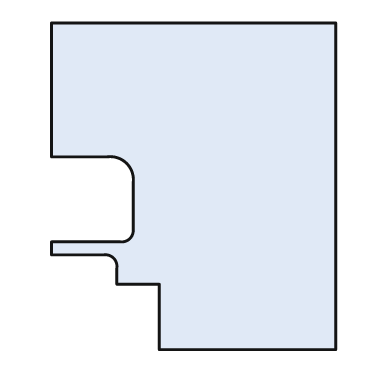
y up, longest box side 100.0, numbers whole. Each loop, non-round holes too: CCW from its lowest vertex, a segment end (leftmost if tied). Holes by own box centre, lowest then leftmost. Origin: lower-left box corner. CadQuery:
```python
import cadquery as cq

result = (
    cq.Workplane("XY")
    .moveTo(33.0, 0.0)
    .lineTo(87.0, 0.0)
    .lineTo(87.0, 100.0)
    .lineTo(0.0, 100.0)
    .lineTo(0.0, 59.0)
    .lineTo(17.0, 59.0)
    .threePointArc((23.0, 57.0), (25.0, 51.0))
    .lineTo(25.0, 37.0)
    .threePointArc((24.0, 34.0), (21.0, 33.0))
    .lineTo(0.0, 33.0)
    .lineTo(0.0, 29.0)
    .lineTo(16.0, 29.0)
    .threePointArc((19.0, 28.0), (20.0, 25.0))
    .lineTo(20.0, 20.0)
    .lineTo(33.0, 20.0)
    .close()
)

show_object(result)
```